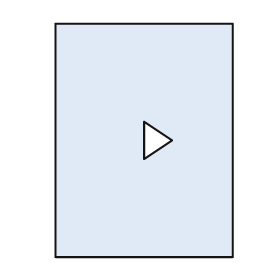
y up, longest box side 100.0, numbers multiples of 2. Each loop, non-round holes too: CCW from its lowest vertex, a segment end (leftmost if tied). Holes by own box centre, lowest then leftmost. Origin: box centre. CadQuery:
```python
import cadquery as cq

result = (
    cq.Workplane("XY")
    .moveTo(-38.0, -50.0)
    .lineTo(38.0, -50.0)
    .lineTo(38.0, 50.0)
    .lineTo(-38.0, 50.0)
    .close()
    .moveTo(0.0, -8.0)
    .lineTo(12.0, 0.0)
    .lineTo(0.0, 8.0)
    .close()
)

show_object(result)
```